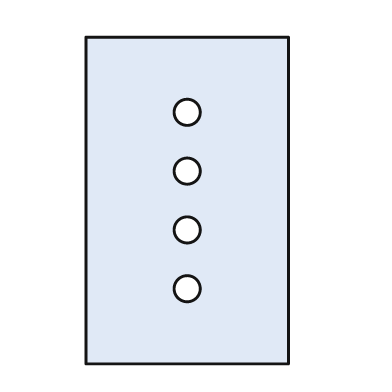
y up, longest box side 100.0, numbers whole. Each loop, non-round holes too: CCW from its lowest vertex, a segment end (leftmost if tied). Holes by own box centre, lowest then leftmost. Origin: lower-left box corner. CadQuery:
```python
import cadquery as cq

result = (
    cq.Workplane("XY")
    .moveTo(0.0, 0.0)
    .lineTo(62.0, 0.0)
    .lineTo(62.0, 100.0)
    .lineTo(0.0, 100.0)
    .close()
    .moveTo(31.0, 23.0)
    .circle(4.0)
    .moveTo(31.0, 41.0)
    .circle(4.0)
    .moveTo(31.0, 59.0)
    .circle(4.0)
    .moveTo(31.0, 77.0)
    .circle(4.0)
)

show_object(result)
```